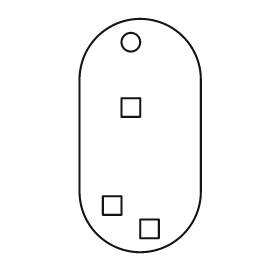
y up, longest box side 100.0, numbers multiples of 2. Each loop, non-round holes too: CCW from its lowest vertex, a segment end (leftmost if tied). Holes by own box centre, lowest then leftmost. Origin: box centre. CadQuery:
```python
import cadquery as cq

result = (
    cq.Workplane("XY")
    .moveTo(-26.0, -24.0)
    .threePointArc((0.0, -50.0), (26.0, -24.0))
    .lineTo(26.0, 24.0)
    .threePointArc((0.0, 50.0), (-26.0, 24.0))
    .close()
    .moveTo(0.0, -44.0)
    .lineTo(8.0, -44.0)
    .lineTo(8.0, -36.0)
    .lineTo(0.0, -36.0)
    .close()
    .moveTo(-16.0, -34.0)
    .lineTo(-8.0, -34.0)
    .lineTo(-8.0, -26.0)
    .lineTo(-16.0, -26.0)
    .close()
    .moveTo(-8.0, 8.0)
    .lineTo(0.0, 8.0)
    .lineTo(0.0, 16.0)
    .lineTo(-8.0, 16.0)
    .close()
    .moveTo(-4.0, 40.0)
    .circle(4.0)
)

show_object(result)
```